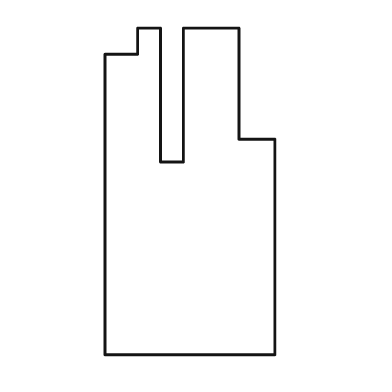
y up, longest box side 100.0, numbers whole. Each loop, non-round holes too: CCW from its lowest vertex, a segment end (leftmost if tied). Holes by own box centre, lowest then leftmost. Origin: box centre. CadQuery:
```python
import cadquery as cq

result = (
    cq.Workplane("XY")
    .moveTo(-26.0, -50.0)
    .lineTo(26.0, -50.0)
    .lineTo(26.0, 16.0)
    .lineTo(15.0, 16.0)
    .lineTo(15.0, 50.0)
    .lineTo(-2.0, 50.0)
    .lineTo(-2.0, 9.0)
    .lineTo(-9.0, 9.0)
    .lineTo(-9.0, 50.0)
    .lineTo(-16.0, 50.0)
    .lineTo(-16.0, 42.0)
    .lineTo(-26.0, 42.0)
    .close()
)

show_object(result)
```